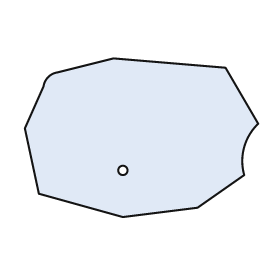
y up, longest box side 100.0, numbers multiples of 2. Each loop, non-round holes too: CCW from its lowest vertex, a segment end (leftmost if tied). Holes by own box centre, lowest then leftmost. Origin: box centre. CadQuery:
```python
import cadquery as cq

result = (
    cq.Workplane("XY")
    .moveTo(-8.0, -34.0)
    .lineTo(24.0, -30.0)
    .lineTo(44.0, -16.0)
    .threePointArc((44.0, -4.0), (50.0, 6.0))
    .lineTo(36.0, 30.0)
    .lineTo(-12.0, 34.0)
    .lineTo(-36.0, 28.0)
    .threePointArc((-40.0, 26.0), (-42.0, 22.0))
    .lineTo(-50.0, 4.0)
    .lineTo(-44.0, -24.0)
    .close()
    .moveTo(-8.0, -14.0)
    .circle(2.0)
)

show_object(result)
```